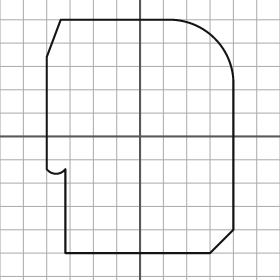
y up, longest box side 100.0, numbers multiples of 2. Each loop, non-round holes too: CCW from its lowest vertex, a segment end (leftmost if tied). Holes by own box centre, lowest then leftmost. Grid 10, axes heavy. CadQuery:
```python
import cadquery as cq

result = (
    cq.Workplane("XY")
    .moveTo(-32.0, -50.0)
    .lineTo(30.0, -50.0)
    .lineTo(40.0, -40.0)
    .lineTo(40.0, 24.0)
    .threePointArc((32.0, 42.0), (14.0, 50.0))
    .lineTo(-34.0, 50.0)
    .lineTo(-40.0, 34.0)
    .lineTo(-40.0, -14.0)
    .threePointArc((-36.0, -16.0), (-32.0, -14.0))
    .close()
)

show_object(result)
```